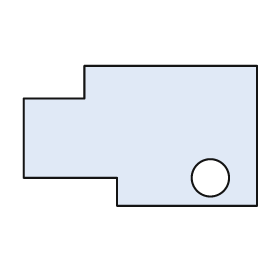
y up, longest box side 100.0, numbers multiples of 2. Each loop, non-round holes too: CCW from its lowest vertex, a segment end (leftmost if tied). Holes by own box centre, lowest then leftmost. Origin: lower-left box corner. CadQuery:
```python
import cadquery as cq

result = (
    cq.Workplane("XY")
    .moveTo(40.0, 0.0)
    .lineTo(100.0, 0.0)
    .lineTo(100.0, 60.0)
    .lineTo(26.0, 60.0)
    .lineTo(26.0, 46.0)
    .lineTo(0.0, 46.0)
    .lineTo(0.0, 12.0)
    .lineTo(40.0, 12.0)
    .close()
    .moveTo(80.0, 12.0)
    .circle(8.0)
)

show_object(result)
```